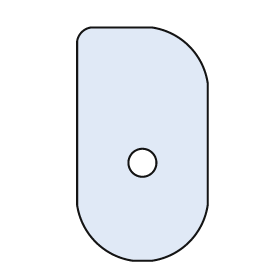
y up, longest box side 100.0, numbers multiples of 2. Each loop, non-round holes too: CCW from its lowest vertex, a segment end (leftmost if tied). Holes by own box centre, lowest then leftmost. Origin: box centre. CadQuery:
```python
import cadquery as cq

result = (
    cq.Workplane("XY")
    .moveTo(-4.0, -50.0)
    .lineTo(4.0, -50.0)
    .threePointArc((20.0, -42.0), (28.0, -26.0))
    .lineTo(28.0, 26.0)
    .threePointArc((20.0, 42.0), (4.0, 50.0))
    .lineTo(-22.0, 50.0)
    .threePointArc((-26.0, 48.0), (-28.0, 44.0))
    .lineTo(-28.0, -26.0)
    .threePointArc((-20.0, -42.0), (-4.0, -50.0))
    .close()
    .moveTo(0.0, -8.0)
    .circle(6.0)
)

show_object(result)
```